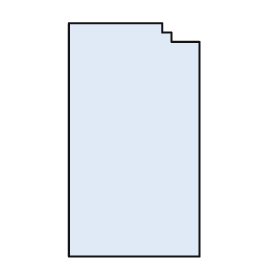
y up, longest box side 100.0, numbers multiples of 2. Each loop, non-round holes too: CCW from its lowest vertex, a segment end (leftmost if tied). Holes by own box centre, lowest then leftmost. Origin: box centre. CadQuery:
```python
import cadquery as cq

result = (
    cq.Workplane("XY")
    .moveTo(-28.0, -50.0)
    .lineTo(28.0, -50.0)
    .lineTo(28.0, 42.0)
    .lineTo(16.0, 42.0)
    .lineTo(16.0, 46.0)
    .lineTo(12.0, 46.0)
    .lineTo(12.0, 50.0)
    .lineTo(-28.0, 50.0)
    .close()
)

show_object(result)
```